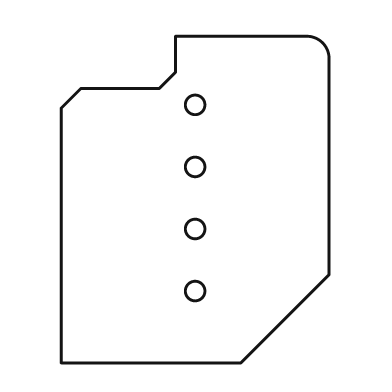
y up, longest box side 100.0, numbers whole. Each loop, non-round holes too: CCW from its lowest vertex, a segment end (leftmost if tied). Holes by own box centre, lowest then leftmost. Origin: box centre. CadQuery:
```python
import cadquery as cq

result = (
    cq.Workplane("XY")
    .moveTo(-41.0, -50.0)
    .lineTo(14.0, -50.0)
    .lineTo(41.0, -23.0)
    .lineTo(41.0, 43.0)
    .threePointArc((39.0, 48.0), (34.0, 50.0))
    .lineTo(-6.0, 50.0)
    .lineTo(-6.0, 39.0)
    .lineTo(-11.0, 34.0)
    .lineTo(-35.0, 34.0)
    .lineTo(-41.0, 28.0)
    .close()
    .moveTo(0.0, -28.0)
    .circle(3.0)
    .moveTo(0.0, -9.0)
    .circle(3.0)
    .moveTo(0.0, 10.0)
    .circle(3.0)
    .moveTo(0.0, 29.0)
    .circle(3.0)
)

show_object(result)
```